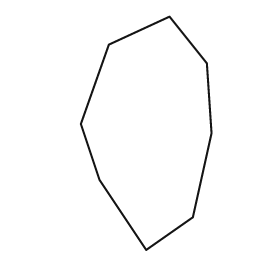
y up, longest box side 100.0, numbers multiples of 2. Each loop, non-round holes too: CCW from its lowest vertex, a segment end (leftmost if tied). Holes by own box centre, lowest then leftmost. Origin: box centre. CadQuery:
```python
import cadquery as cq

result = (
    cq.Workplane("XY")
    .moveTo(0.0, -50.0)
    .lineTo(20.0, -36.0)
    .lineTo(28.0, 0.0)
    .lineTo(26.0, 30.0)
    .lineTo(10.0, 50.0)
    .lineTo(-16.0, 38.0)
    .lineTo(-28.0, 4.0)
    .lineTo(-20.0, -20.0)
    .close()
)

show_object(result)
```